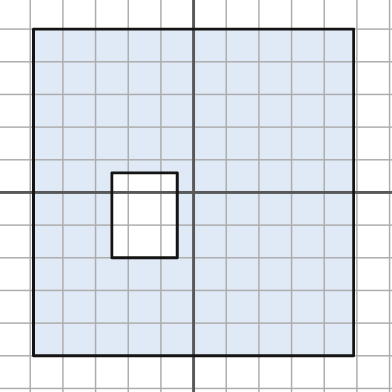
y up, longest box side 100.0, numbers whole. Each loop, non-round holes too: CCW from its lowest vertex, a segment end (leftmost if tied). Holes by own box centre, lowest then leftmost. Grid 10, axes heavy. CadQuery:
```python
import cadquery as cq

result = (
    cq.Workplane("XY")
    .moveTo(-49.0, -50.0)
    .lineTo(49.0, -50.0)
    .lineTo(49.0, 50.0)
    .lineTo(-49.0, 50.0)
    .close()
    .moveTo(-25.0, -20.0)
    .lineTo(-5.0, -20.0)
    .lineTo(-5.0, 6.0)
    .lineTo(-25.0, 6.0)
    .close()
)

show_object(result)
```